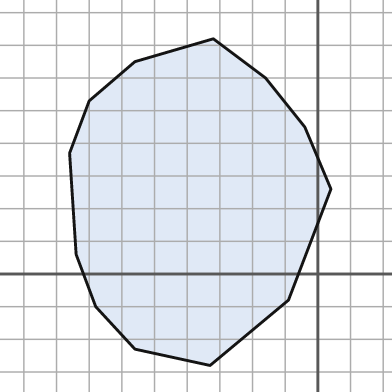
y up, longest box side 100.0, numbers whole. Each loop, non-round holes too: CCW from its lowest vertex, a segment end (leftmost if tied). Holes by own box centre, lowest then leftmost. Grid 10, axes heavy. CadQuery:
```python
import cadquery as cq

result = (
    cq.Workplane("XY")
    .moveTo(-33.0, -28.0)
    .lineTo(-9.0, -8.0)
    .lineTo(4.0, 26.0)
    .lineTo(-4.0, 45.0)
    .lineTo(-16.0, 60.0)
    .lineTo(-32.0, 72.0)
    .lineTo(-56.0, 65.0)
    .lineTo(-70.0, 53.0)
    .lineTo(-76.0, 37.0)
    .lineTo(-74.0, 6.0)
    .lineTo(-68.0, -10.0)
    .lineTo(-56.0, -23.0)
    .close()
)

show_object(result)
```